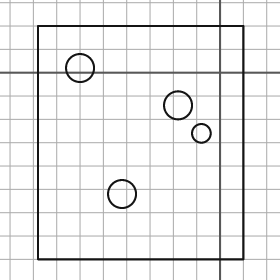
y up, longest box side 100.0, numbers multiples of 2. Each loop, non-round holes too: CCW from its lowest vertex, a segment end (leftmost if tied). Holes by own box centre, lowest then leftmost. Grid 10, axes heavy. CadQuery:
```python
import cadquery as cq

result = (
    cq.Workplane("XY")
    .moveTo(-78.0, -80.0)
    .lineTo(10.0, -80.0)
    .lineTo(10.0, 20.0)
    .lineTo(-78.0, 20.0)
    .close()
    .moveTo(-42.0, -52.0)
    .circle(6.0)
    .moveTo(-8.0, -26.0)
    .circle(4.0)
    .moveTo(-18.0, -14.0)
    .circle(6.0)
    .moveTo(-60.0, 2.0)
    .circle(6.0)
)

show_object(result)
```